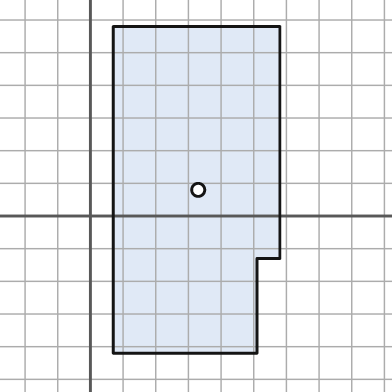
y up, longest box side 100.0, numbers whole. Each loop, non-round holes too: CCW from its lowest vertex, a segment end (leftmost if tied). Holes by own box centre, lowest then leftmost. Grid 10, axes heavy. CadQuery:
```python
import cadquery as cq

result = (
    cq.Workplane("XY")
    .moveTo(7.0, -42.0)
    .lineTo(51.0, -42.0)
    .lineTo(51.0, -13.0)
    .lineTo(58.0, -13.0)
    .lineTo(58.0, 58.0)
    .lineTo(7.0, 58.0)
    .close()
    .moveTo(33.0, 8.0)
    .circle(2.0)
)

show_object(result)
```